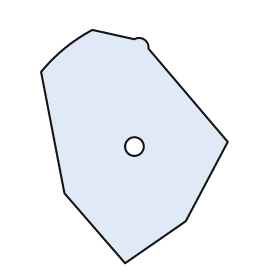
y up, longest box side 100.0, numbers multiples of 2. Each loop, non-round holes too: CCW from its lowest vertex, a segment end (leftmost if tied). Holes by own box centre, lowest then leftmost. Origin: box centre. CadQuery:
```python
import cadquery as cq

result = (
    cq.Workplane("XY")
    .moveTo(-4.0, -50.0)
    .lineTo(22.0, -32.0)
    .lineTo(40.0, 2.0)
    .lineTo(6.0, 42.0)
    .threePointArc((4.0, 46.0), (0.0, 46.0))
    .lineTo(-18.0, 50.0)
    .threePointArc((-30.0, 42.0), (-40.0, 32.0))
    .lineTo(-30.0, -20.0)
    .close()
    .moveTo(0.0, 0.0)
    .circle(4.0)
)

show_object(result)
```